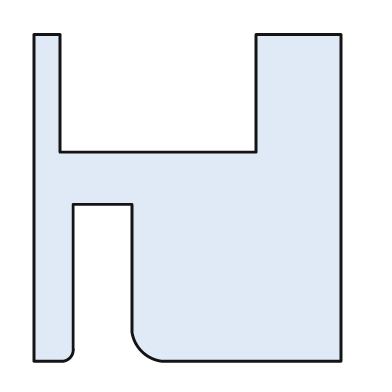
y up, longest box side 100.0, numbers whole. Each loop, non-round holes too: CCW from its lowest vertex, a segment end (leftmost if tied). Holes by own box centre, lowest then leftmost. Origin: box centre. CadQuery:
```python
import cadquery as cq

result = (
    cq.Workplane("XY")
    .moveTo(-47.0, -50.0)
    .lineTo(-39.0, -50.0)
    .threePointArc((-36.0, -49.0), (-35.0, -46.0))
    .lineTo(-35.0, -2.0)
    .lineTo(-17.0, -2.0)
    .lineTo(-17.0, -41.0)
    .threePointArc((-14.0, -47.0), (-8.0, -50.0))
    .lineTo(47.0, -50.0)
    .lineTo(47.0, 50.0)
    .lineTo(21.0, 50.0)
    .lineTo(21.0, 14.0)
    .lineTo(-39.0, 14.0)
    .lineTo(-39.0, 50.0)
    .lineTo(-47.0, 50.0)
    .close()
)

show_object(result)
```